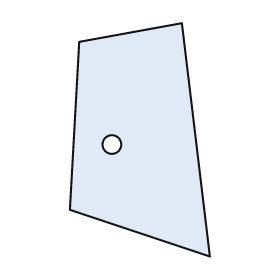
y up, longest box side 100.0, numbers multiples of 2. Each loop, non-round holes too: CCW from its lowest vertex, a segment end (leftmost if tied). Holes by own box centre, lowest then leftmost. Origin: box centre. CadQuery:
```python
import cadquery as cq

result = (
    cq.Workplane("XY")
    .moveTo(30.0, -50.0)
    .lineTo(18.0, 50.0)
    .lineTo(-26.0, 42.0)
    .lineTo(-30.0, -30.0)
    .close()
    .moveTo(-12.0, -2.0)
    .circle(4.0)
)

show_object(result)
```